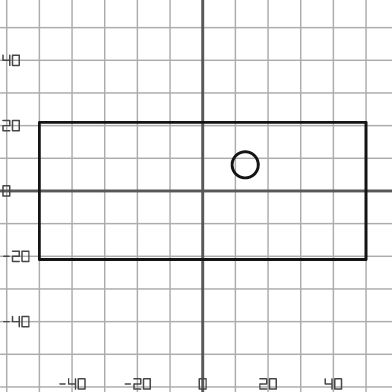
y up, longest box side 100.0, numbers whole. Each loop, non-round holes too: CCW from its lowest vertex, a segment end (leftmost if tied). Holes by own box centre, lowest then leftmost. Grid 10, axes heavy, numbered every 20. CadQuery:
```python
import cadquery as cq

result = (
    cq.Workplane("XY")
    .moveTo(-50.0, -21.0)
    .lineTo(50.0, -21.0)
    .lineTo(50.0, 21.0)
    .lineTo(-50.0, 21.0)
    .close()
    .moveTo(13.0, 8.0)
    .circle(4.0)
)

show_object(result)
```